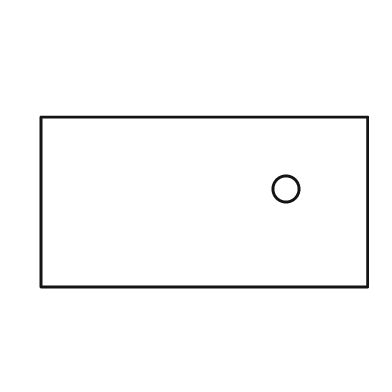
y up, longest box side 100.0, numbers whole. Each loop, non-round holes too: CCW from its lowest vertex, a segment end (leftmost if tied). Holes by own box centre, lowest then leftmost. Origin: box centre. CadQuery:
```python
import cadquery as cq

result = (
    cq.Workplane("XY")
    .moveTo(-50.0, -26.0)
    .lineTo(50.0, -26.0)
    .lineTo(50.0, 26.0)
    .lineTo(-50.0, 26.0)
    .close()
    .moveTo(25.0, 4.0)
    .circle(4.0)
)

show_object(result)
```